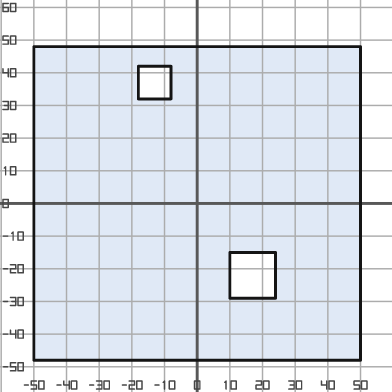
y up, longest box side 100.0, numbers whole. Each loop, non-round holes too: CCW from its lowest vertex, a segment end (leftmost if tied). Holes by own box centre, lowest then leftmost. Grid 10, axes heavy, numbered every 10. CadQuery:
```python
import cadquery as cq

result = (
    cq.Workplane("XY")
    .moveTo(-50.0, -48.0)
    .lineTo(50.0, -48.0)
    .lineTo(50.0, 48.0)
    .lineTo(-50.0, 48.0)
    .close()
    .moveTo(10.0, -29.0)
    .lineTo(24.0, -29.0)
    .lineTo(24.0, -15.0)
    .lineTo(10.0, -15.0)
    .close()
    .moveTo(-18.0, 32.0)
    .lineTo(-8.0, 32.0)
    .lineTo(-8.0, 42.0)
    .lineTo(-18.0, 42.0)
    .close()
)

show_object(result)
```